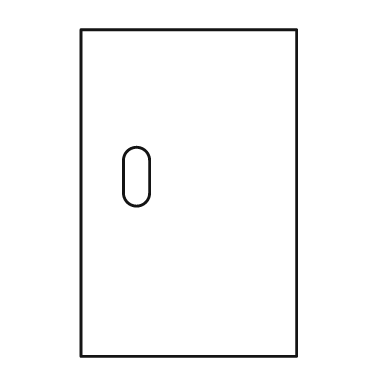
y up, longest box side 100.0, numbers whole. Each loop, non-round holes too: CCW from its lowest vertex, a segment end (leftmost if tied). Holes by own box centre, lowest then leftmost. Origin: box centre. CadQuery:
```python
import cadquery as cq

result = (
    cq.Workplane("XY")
    .moveTo(-33.0, -50.0)
    .lineTo(33.0, -50.0)
    .lineTo(33.0, 50.0)
    .lineTo(-33.0, 50.0)
    .close()
    .moveTo(-20.0, 0.0)
    .threePointArc((-16.0, -4.0), (-12.0, 0.0))
    .lineTo(-12.0, 10.0)
    .threePointArc((-16.0, 14.0), (-20.0, 10.0))
    .close()
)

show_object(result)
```